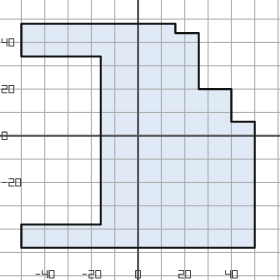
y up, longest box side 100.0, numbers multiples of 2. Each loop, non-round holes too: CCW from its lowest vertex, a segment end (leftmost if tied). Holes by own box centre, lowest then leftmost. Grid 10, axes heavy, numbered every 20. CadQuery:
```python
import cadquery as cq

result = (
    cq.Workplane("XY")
    .moveTo(-50.0, -48.0)
    .lineTo(50.0, -48.0)
    .lineTo(50.0, 6.0)
    .lineTo(40.0, 6.0)
    .lineTo(40.0, 20.0)
    .lineTo(26.0, 20.0)
    .lineTo(26.0, 44.0)
    .lineTo(16.0, 44.0)
    .lineTo(16.0, 48.0)
    .lineTo(-50.0, 48.0)
    .lineTo(-50.0, 34.0)
    .lineTo(-16.0, 34.0)
    .lineTo(-16.0, -38.0)
    .lineTo(-50.0, -38.0)
    .close()
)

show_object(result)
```